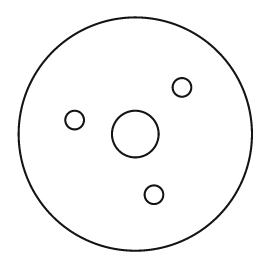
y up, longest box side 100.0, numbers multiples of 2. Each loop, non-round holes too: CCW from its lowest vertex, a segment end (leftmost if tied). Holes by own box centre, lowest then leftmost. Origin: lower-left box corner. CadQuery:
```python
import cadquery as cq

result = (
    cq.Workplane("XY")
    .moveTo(50.0, 50.0)
    .circle(50.0)
    .moveTo(58.0, 24.0)
    .circle(4.0)
    .moveTo(50.0, 50.0)
    .circle(10.0)
    .moveTo(24.0, 56.0)
    .circle(4.0)
    .moveTo(70.0, 70.0)
    .circle(4.0)
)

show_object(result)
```